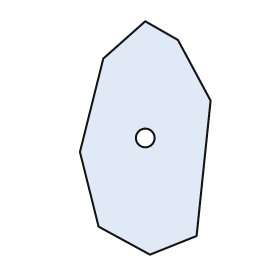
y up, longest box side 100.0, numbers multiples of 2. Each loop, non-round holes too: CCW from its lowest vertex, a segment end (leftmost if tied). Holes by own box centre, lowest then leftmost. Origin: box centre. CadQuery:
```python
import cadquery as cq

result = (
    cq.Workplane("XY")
    .moveTo(2.0, -50.0)
    .lineTo(22.0, -42.0)
    .lineTo(28.0, 16.0)
    .lineTo(14.0, 42.0)
    .lineTo(0.0, 50.0)
    .lineTo(-18.0, 34.0)
    .lineTo(-28.0, -6.0)
    .lineTo(-20.0, -38.0)
    .close()
    .moveTo(0.0, 0.0)
    .circle(4.0)
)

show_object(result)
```